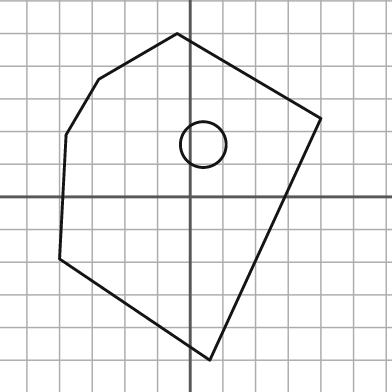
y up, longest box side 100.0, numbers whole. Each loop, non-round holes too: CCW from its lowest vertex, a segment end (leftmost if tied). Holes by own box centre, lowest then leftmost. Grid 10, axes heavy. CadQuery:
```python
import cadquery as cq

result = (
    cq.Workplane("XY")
    .moveTo(6.0, -50.0)
    .lineTo(40.0, 24.0)
    .lineTo(-4.0, 50.0)
    .lineTo(-28.0, 36.0)
    .lineTo(-38.0, 19.0)
    .lineTo(-40.0, -19.0)
    .close()
    .moveTo(4.0, 16.0)
    .circle(7.0)
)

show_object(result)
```